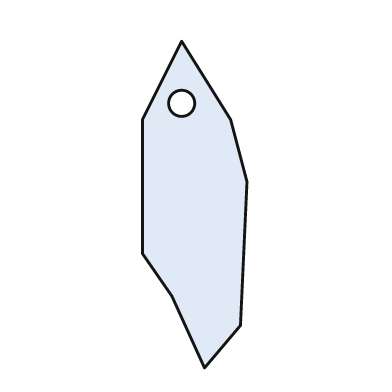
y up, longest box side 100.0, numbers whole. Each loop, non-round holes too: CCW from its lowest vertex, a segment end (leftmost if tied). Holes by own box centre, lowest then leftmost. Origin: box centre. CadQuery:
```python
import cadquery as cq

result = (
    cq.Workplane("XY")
    .moveTo(3.0, -50.0)
    .lineTo(14.0, -37.0)
    .lineTo(16.0, 7.0)
    .lineTo(11.0, 26.0)
    .lineTo(-4.0, 50.0)
    .lineTo(-16.0, 26.0)
    .lineTo(-16.0, -15.0)
    .lineTo(-7.0, -28.0)
    .close()
    .moveTo(-4.0, 31.0)
    .circle(4.0)
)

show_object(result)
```